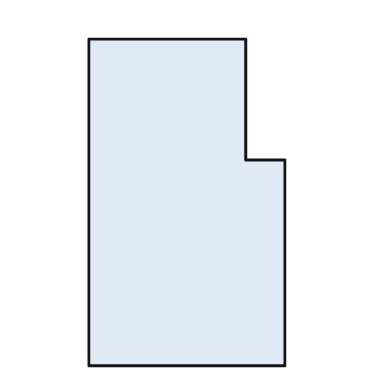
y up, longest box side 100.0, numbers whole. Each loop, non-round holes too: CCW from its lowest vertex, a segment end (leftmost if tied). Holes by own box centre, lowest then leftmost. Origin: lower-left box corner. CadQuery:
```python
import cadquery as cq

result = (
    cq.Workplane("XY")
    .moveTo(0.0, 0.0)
    .lineTo(60.0, 0.0)
    .lineTo(60.0, 63.0)
    .lineTo(48.0, 63.0)
    .lineTo(48.0, 100.0)
    .lineTo(0.0, 100.0)
    .close()
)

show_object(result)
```